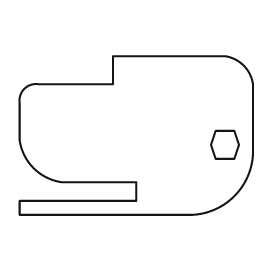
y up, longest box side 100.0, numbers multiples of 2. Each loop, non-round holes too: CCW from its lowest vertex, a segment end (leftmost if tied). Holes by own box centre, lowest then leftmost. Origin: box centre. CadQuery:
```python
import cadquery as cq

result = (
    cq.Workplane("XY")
    .moveTo(-50.0, -34.0)
    .lineTo(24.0, -34.0)
    .threePointArc((42.0, -26.0), (50.0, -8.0))
    .lineTo(50.0, 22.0)
    .threePointArc((46.0, 30.0), (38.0, 34.0))
    .lineTo(-10.0, 34.0)
    .lineTo(-10.0, 22.0)
    .lineTo(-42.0, 22.0)
    .threePointArc((-48.0, 20.0), (-50.0, 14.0))
    .lineTo(-50.0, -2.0)
    .threePointArc((-44.0, -14.0), (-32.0, -20.0))
    .lineTo(0.0, -20.0)
    .lineTo(0.0, -28.0)
    .lineTo(-50.0, -28.0)
    .close()
    .moveTo(34.0, -10.0)
    .lineTo(42.0, -10.0)
    .lineTo(44.0, -4.0)
    .lineTo(42.0, 2.0)
    .lineTo(34.0, 2.0)
    .lineTo(32.0, -4.0)
    .close()
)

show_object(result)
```